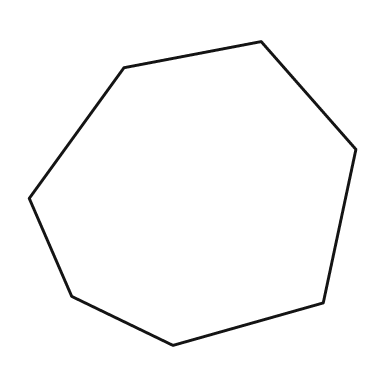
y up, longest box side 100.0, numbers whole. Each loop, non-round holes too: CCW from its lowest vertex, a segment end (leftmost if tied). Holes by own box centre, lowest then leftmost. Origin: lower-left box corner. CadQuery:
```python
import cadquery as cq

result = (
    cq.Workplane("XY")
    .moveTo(44.0, 0.0)
    .lineTo(90.0, 13.0)
    .lineTo(100.0, 60.0)
    .lineTo(71.0, 93.0)
    .lineTo(29.0, 85.0)
    .lineTo(0.0, 45.0)
    .lineTo(13.0, 15.0)
    .close()
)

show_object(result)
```